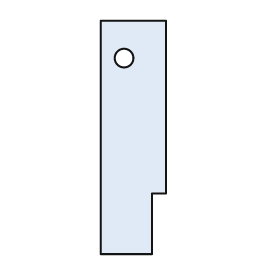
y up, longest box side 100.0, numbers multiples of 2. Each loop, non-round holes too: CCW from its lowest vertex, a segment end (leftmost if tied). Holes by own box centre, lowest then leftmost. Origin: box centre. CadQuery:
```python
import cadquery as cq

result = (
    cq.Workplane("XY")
    .moveTo(-14.0, -50.0)
    .lineTo(8.0, -50.0)
    .lineTo(8.0, -24.0)
    .lineTo(14.0, -24.0)
    .lineTo(14.0, 50.0)
    .lineTo(-14.0, 50.0)
    .close()
    .moveTo(-4.0, 34.0)
    .circle(4.0)
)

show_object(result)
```